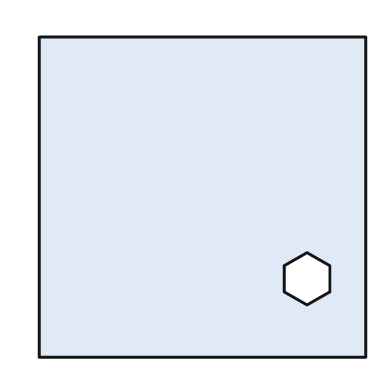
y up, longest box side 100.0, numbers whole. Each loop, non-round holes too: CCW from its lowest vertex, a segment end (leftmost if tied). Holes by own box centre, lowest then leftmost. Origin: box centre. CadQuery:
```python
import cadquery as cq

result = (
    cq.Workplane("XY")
    .moveTo(-50.0, -49.0)
    .lineTo(50.0, -49.0)
    .lineTo(50.0, 49.0)
    .lineTo(-50.0, 49.0)
    .close()
    .moveTo(32.0, -33.0)
    .lineTo(39.0, -29.0)
    .lineTo(39.0, -21.0)
    .lineTo(32.0, -17.0)
    .lineTo(25.0, -21.0)
    .lineTo(25.0, -29.0)
    .close()
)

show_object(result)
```